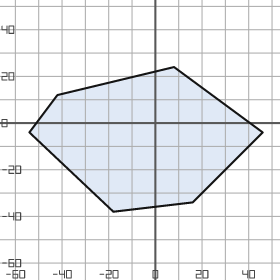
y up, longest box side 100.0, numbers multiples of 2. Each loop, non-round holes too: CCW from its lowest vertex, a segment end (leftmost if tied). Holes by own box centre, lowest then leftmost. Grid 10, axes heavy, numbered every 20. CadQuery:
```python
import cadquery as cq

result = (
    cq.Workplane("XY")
    .moveTo(-18.0, -38.0)
    .lineTo(16.0, -34.0)
    .lineTo(46.0, -4.0)
    .lineTo(8.0, 24.0)
    .lineTo(-42.0, 12.0)
    .lineTo(-54.0, -4.0)
    .close()
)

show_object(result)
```